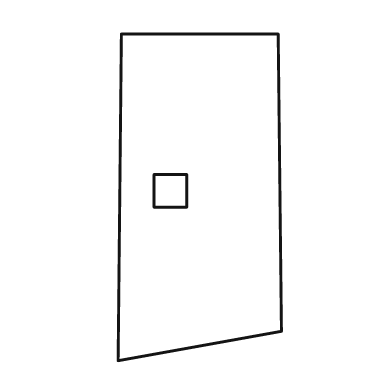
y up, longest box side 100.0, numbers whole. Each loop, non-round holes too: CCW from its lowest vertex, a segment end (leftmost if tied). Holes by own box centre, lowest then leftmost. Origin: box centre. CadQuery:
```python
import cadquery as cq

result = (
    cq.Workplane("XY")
    .moveTo(-25.0, -50.0)
    .lineTo(25.0, -41.0)
    .lineTo(24.0, 50.0)
    .lineTo(-24.0, 50.0)
    .close()
    .moveTo(-14.0, -3.0)
    .lineTo(-4.0, -3.0)
    .lineTo(-4.0, 7.0)
    .lineTo(-14.0, 7.0)
    .close()
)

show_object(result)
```